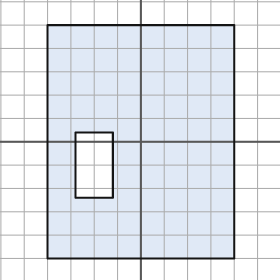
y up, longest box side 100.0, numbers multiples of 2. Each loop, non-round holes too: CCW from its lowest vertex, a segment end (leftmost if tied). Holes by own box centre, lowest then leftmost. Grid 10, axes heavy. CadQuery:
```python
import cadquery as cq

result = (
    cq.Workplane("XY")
    .moveTo(-40.0, -50.0)
    .lineTo(40.0, -50.0)
    .lineTo(40.0, 50.0)
    .lineTo(-40.0, 50.0)
    .close()
    .moveTo(-28.0, -24.0)
    .lineTo(-12.0, -24.0)
    .lineTo(-12.0, 4.0)
    .lineTo(-28.0, 4.0)
    .close()
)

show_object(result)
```